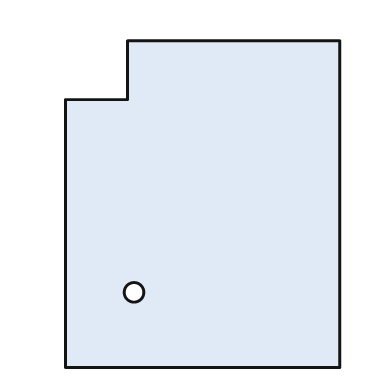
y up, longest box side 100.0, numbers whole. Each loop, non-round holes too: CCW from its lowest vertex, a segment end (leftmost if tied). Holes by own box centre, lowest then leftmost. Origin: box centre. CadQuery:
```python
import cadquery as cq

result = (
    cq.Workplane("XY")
    .moveTo(-42.0, -50.0)
    .lineTo(42.0, -50.0)
    .lineTo(42.0, 50.0)
    .lineTo(-23.0, 50.0)
    .lineTo(-23.0, 32.0)
    .lineTo(-42.0, 32.0)
    .close()
    .moveTo(-21.0, -27.0)
    .circle(3.0)
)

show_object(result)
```